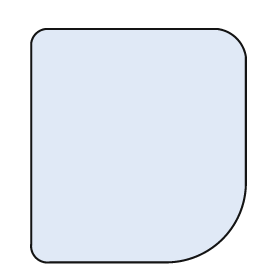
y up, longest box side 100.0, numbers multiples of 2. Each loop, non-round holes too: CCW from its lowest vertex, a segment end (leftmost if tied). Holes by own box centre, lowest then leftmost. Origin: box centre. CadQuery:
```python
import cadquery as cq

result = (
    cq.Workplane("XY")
    .moveTo(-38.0, -50.0)
    .lineTo(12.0, -50.0)
    .threePointArc((36.0, -40.0), (46.0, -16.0))
    .lineTo(46.0, 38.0)
    .threePointArc((42.0, 46.0), (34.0, 50.0))
    .lineTo(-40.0, 50.0)
    .threePointArc((-44.0, 48.0), (-46.0, 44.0))
    .lineTo(-46.0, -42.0)
    .threePointArc((-44.0, -48.0), (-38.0, -50.0))
    .close()
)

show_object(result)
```